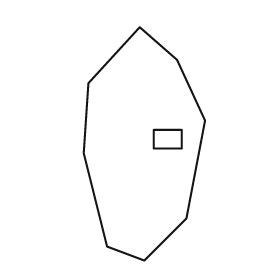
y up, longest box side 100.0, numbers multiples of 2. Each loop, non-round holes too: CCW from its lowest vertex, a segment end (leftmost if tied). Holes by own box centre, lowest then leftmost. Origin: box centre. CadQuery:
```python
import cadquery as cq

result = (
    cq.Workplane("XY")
    .moveTo(0.0, -50.0)
    .lineTo(18.0, -32.0)
    .lineTo(26.0, 10.0)
    .lineTo(14.0, 36.0)
    .lineTo(-2.0, 50.0)
    .lineTo(-24.0, 26.0)
    .lineTo(-26.0, -4.0)
    .lineTo(-16.0, -44.0)
    .close()
    .moveTo(4.0, -2.0)
    .lineTo(16.0, -2.0)
    .lineTo(16.0, 6.0)
    .lineTo(4.0, 6.0)
    .close()
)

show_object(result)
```